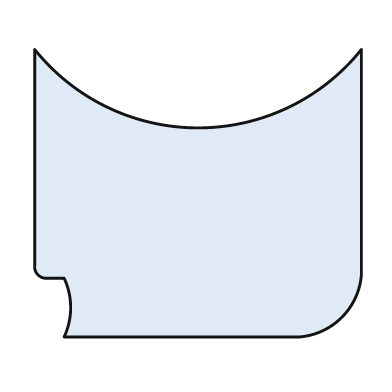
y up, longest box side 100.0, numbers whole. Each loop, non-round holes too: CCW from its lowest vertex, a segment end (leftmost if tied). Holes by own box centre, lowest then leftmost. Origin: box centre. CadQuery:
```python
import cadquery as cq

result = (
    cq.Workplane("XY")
    .moveTo(-41.0, -44.0)
    .lineTo(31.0, -44.0)
    .threePointArc((44.0, -38.0), (50.0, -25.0))
    .lineTo(50.0, 44.0)
    .threePointArc((0.0, 20.0), (-50.0, 44.0))
    .lineTo(-50.0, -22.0)
    .threePointArc((-49.0, -25.0), (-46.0, -26.0))
    .lineTo(-41.0, -26.0)
    .threePointArc((-39.0, -35.0), (-41.0, -44.0))
    .close()
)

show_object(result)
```